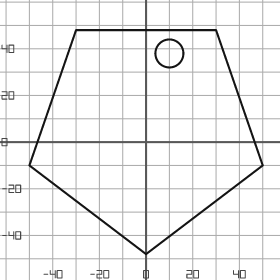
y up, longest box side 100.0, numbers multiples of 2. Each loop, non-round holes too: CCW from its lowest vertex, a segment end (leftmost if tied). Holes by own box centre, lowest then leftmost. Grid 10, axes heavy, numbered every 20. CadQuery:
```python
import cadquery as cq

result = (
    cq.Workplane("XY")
    .moveTo(0.0, -48.0)
    .lineTo(50.0, -10.0)
    .lineTo(30.0, 48.0)
    .lineTo(-30.0, 48.0)
    .lineTo(-50.0, -10.0)
    .close()
    .moveTo(10.0, 38.0)
    .circle(6.0)
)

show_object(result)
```